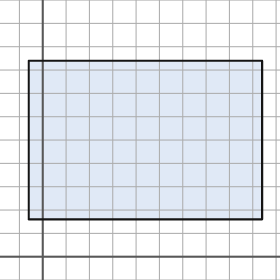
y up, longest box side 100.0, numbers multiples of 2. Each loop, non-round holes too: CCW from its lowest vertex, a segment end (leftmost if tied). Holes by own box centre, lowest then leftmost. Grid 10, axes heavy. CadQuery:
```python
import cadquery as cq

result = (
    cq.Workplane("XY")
    .moveTo(-6.0, 16.0)
    .lineTo(94.0, 16.0)
    .lineTo(94.0, 84.0)
    .lineTo(-6.0, 84.0)
    .close()
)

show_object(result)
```